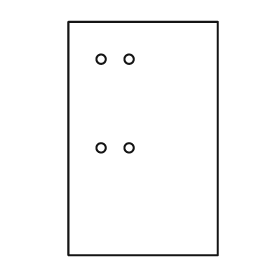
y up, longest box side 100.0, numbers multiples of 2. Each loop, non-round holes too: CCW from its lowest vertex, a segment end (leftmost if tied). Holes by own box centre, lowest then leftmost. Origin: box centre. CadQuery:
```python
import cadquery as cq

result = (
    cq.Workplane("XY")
    .moveTo(-32.0, -50.0)
    .lineTo(32.0, -50.0)
    .lineTo(32.0, 50.0)
    .lineTo(-32.0, 50.0)
    .close()
    .moveTo(-18.0, -4.0)
    .circle(2.0)
    .moveTo(-6.0, -4.0)
    .circle(2.0)
    .moveTo(-18.0, 34.0)
    .circle(2.0)
    .moveTo(-6.0, 34.0)
    .circle(2.0)
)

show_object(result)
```